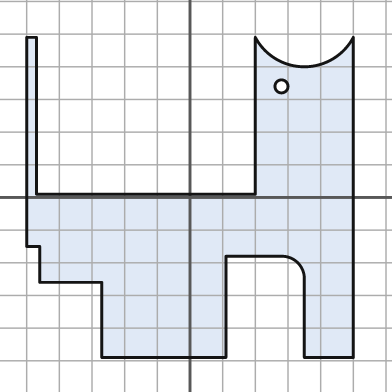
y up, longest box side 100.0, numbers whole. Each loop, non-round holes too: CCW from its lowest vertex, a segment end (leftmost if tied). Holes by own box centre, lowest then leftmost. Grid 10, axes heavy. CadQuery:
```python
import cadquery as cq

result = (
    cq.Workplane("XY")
    .moveTo(-27.0, -49.0)
    .lineTo(11.0, -49.0)
    .lineTo(11.0, -18.0)
    .lineTo(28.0, -18.0)
    .threePointArc((33.0, -20.0), (35.0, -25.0))
    .lineTo(35.0, -49.0)
    .lineTo(50.0, -49.0)
    .lineTo(50.0, 49.0)
    .threePointArc((35.0, 40.0), (20.0, 49.0))
    .lineTo(20.0, 1.0)
    .lineTo(-47.0, 1.0)
    .lineTo(-47.0, 49.0)
    .lineTo(-50.0, 49.0)
    .lineTo(-50.0, -15.0)
    .lineTo(-46.0, -15.0)
    .lineTo(-46.0, -26.0)
    .lineTo(-27.0, -26.0)
    .close()
    .moveTo(28.0, 34.0)
    .circle(2.0)
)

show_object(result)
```